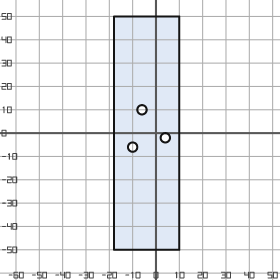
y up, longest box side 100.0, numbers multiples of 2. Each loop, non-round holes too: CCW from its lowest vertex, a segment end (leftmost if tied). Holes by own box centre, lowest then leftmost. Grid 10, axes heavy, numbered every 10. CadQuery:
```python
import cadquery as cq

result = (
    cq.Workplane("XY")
    .moveTo(-18.0, -50.0)
    .lineTo(10.0, -50.0)
    .lineTo(10.0, 50.0)
    .lineTo(-18.0, 50.0)
    .close()
    .moveTo(-10.0, -6.0)
    .circle(2.0)
    .moveTo(4.0, -2.0)
    .circle(2.0)
    .moveTo(-6.0, 10.0)
    .circle(2.0)
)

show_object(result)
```